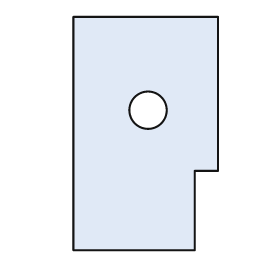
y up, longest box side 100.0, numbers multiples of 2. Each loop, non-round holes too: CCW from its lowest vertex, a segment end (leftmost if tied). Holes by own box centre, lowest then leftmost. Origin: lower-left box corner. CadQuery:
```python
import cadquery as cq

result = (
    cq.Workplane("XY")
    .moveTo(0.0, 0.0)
    .lineTo(52.0, 0.0)
    .lineTo(52.0, 34.0)
    .lineTo(62.0, 34.0)
    .lineTo(62.0, 100.0)
    .lineTo(0.0, 100.0)
    .close()
    .moveTo(32.0, 60.0)
    .circle(8.0)
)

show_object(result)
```